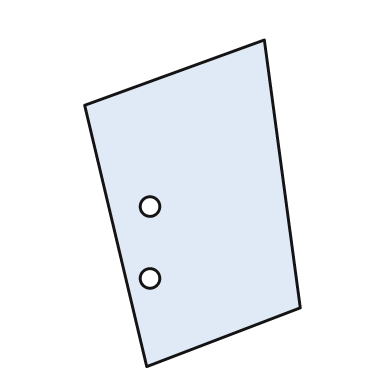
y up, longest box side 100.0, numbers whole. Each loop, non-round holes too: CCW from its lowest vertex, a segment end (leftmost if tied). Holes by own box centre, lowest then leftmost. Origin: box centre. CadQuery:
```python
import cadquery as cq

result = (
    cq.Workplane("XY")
    .moveTo(-14.0, -50.0)
    .lineTo(33.0, -32.0)
    .lineTo(22.0, 50.0)
    .lineTo(-33.0, 30.0)
    .close()
    .moveTo(-13.0, -23.0)
    .circle(3.0)
    .moveTo(-13.0, -1.0)
    .circle(3.0)
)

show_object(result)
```